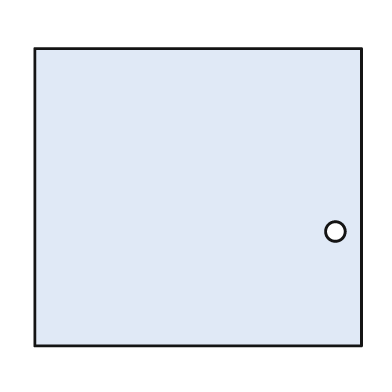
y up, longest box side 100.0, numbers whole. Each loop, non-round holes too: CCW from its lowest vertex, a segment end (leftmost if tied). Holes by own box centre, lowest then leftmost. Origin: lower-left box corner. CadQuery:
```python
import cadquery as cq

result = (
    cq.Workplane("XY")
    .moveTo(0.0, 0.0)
    .lineTo(100.0, 0.0)
    .lineTo(100.0, 91.0)
    .lineTo(0.0, 91.0)
    .close()
    .moveTo(92.0, 35.0)
    .circle(3.0)
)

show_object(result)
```